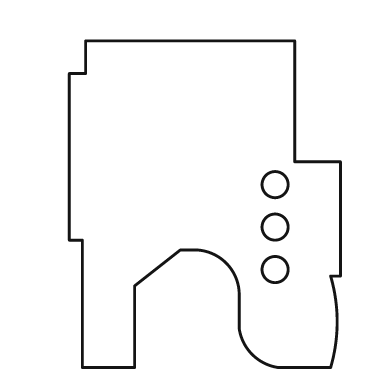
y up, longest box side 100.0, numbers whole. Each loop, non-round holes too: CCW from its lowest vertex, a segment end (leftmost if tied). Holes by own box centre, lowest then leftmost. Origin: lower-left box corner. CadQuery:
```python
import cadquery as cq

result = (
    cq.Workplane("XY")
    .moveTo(4.0, 0.0)
    .lineTo(20.0, 0.0)
    .lineTo(20.0, 25.0)
    .lineTo(34.0, 36.0)
    .lineTo(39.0, 36.0)
    .threePointArc((48.0, 32.0), (52.0, 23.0))
    .lineTo(52.0, 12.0)
    .threePointArc((56.0, 4.0), (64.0, 0.0))
    .lineTo(80.0, 0.0)
    .threePointArc((82.0, 14.0), (80.0, 28.0))
    .lineTo(83.0, 28.0)
    .lineTo(83.0, 63.0)
    .lineTo(69.0, 63.0)
    .lineTo(69.0, 100.0)
    .lineTo(5.0, 100.0)
    .lineTo(5.0, 90.0)
    .lineTo(0.0, 90.0)
    .lineTo(0.0, 39.0)
    .lineTo(4.0, 39.0)
    .close()
    .moveTo(63.0, 30.0)
    .circle(4.0)
    .moveTo(63.0, 43.0)
    .circle(4.0)
    .moveTo(63.0, 56.0)
    .circle(4.0)
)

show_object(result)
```